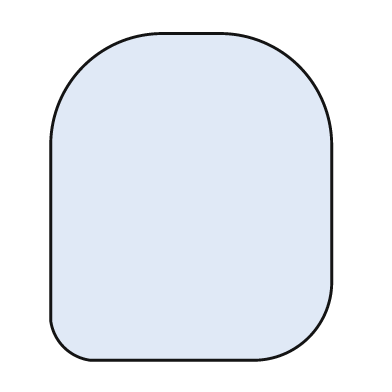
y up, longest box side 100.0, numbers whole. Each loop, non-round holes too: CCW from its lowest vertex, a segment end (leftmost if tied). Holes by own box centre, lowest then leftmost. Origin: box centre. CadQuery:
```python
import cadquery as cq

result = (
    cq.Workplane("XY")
    .moveTo(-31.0, -50.0)
    .lineTo(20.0, -50.0)
    .threePointArc((36.0, -43.0), (43.0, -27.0))
    .lineTo(43.0, 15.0)
    .threePointArc((33.0, 40.0), (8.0, 50.0))
    .lineTo(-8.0, 50.0)
    .threePointArc((-33.0, 40.0), (-43.0, 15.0))
    .lineTo(-43.0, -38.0)
    .threePointArc((-39.0, -46.0), (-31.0, -50.0))
    .close()
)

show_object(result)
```